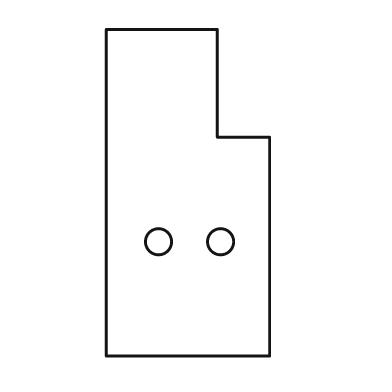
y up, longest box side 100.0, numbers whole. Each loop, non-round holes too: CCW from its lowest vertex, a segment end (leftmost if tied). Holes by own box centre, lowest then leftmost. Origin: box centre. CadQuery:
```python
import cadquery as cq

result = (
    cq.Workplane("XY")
    .moveTo(-25.0, -50.0)
    .lineTo(25.0, -50.0)
    .lineTo(25.0, 17.0)
    .lineTo(9.0, 17.0)
    .lineTo(9.0, 50.0)
    .lineTo(-25.0, 50.0)
    .close()
    .moveTo(-9.0, -15.0)
    .circle(4.0)
    .moveTo(10.0, -15.0)
    .circle(4.0)
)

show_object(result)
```